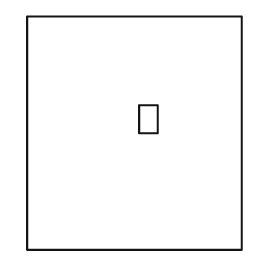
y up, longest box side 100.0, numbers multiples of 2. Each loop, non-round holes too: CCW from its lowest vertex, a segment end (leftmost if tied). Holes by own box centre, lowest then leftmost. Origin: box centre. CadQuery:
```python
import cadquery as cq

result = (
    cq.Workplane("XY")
    .moveTo(-46.0, -50.0)
    .lineTo(46.0, -50.0)
    .lineTo(46.0, 50.0)
    .lineTo(-46.0, 50.0)
    .close()
    .moveTo(2.0, 0.0)
    .lineTo(10.0, 0.0)
    .lineTo(10.0, 12.0)
    .lineTo(2.0, 12.0)
    .close()
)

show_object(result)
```